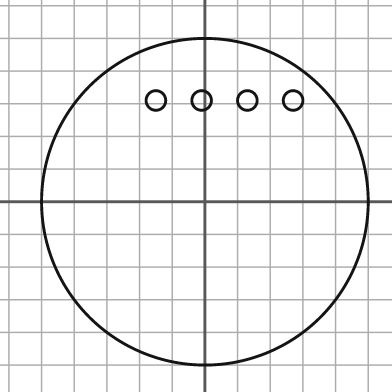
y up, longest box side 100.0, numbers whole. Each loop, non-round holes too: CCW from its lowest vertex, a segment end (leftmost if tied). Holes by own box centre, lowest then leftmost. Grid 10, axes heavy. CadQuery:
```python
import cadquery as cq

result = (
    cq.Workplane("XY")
    .moveTo(0.0, 0.0)
    .circle(50.0)
    .moveTo(-15.0, 31.0)
    .circle(3.0)
    .moveTo(-1.0, 31.0)
    .circle(3.0)
    .moveTo(13.0, 31.0)
    .circle(3.0)
    .moveTo(27.0, 31.0)
    .circle(3.0)
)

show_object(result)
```